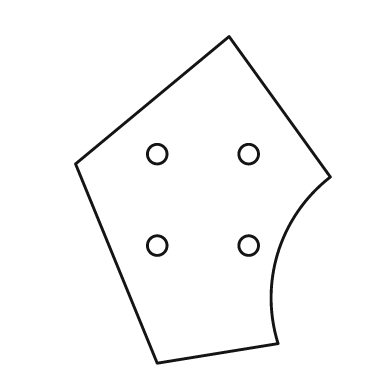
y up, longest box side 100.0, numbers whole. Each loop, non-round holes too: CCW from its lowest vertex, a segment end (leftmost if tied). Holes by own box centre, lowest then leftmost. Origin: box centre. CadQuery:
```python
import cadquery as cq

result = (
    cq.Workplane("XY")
    .moveTo(-14.0, -50.0)
    .lineTo(23.0, -44.0)
    .threePointArc((23.0, -16.0), (39.0, 7.0))
    .lineTo(8.0, 50.0)
    .lineTo(-39.0, 11.0)
    .close()
    .moveTo(-14.0, -14.0)
    .circle(3.0)
    .moveTo(14.0, -14.0)
    .circle(3.0)
    .moveTo(-14.0, 14.0)
    .circle(3.0)
    .moveTo(14.0, 14.0)
    .circle(3.0)
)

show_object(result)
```